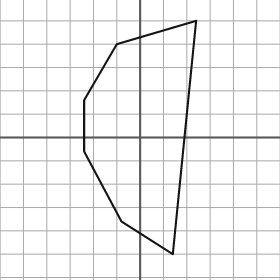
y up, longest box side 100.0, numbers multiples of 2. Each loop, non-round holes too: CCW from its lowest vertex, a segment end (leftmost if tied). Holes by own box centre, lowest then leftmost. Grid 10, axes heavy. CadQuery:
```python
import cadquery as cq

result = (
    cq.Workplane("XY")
    .moveTo(14.0, -50.0)
    .lineTo(24.0, 50.0)
    .lineTo(-10.0, 40.0)
    .lineTo(-24.0, 16.0)
    .lineTo(-24.0, -6.0)
    .lineTo(-8.0, -36.0)
    .close()
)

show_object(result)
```